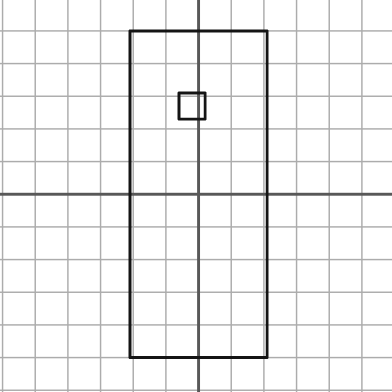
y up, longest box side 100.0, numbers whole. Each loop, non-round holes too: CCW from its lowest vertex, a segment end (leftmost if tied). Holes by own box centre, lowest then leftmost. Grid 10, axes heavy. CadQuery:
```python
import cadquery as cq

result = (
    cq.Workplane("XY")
    .moveTo(-21.0, -50.0)
    .lineTo(21.0, -50.0)
    .lineTo(21.0, 50.0)
    .lineTo(-21.0, 50.0)
    .close()
    .moveTo(-6.0, 23.0)
    .lineTo(2.0, 23.0)
    .lineTo(2.0, 31.0)
    .lineTo(-6.0, 31.0)
    .close()
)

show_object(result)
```